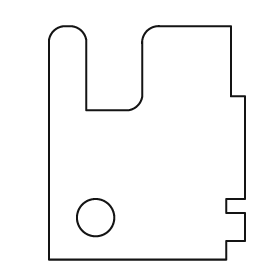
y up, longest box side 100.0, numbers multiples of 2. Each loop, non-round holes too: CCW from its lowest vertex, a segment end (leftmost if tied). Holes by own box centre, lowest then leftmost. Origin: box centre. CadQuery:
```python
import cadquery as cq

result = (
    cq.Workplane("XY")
    .moveTo(-42.0, -50.0)
    .lineTo(34.0, -50.0)
    .lineTo(34.0, -42.0)
    .lineTo(42.0, -42.0)
    .lineTo(42.0, -30.0)
    .lineTo(34.0, -30.0)
    .lineTo(34.0, -24.0)
    .lineTo(42.0, -24.0)
    .lineTo(42.0, 20.0)
    .lineTo(36.0, 20.0)
    .lineTo(36.0, 50.0)
    .lineTo(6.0, 50.0)
    .threePointArc((0.0, 48.0), (-2.0, 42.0))
    .lineTo(-2.0, 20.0)
    .threePointArc((-4.0, 16.0), (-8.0, 14.0))
    .lineTo(-26.0, 14.0)
    .lineTo(-26.0, 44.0)
    .threePointArc((-28.0, 48.0), (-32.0, 50.0))
    .lineTo(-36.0, 50.0)
    .threePointArc((-40.0, 48.0), (-42.0, 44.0))
    .close()
    .moveTo(-22.0, -32.0)
    .circle(8.0)
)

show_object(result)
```